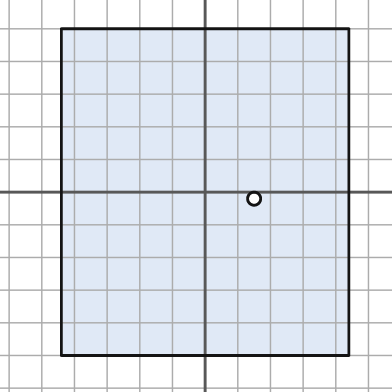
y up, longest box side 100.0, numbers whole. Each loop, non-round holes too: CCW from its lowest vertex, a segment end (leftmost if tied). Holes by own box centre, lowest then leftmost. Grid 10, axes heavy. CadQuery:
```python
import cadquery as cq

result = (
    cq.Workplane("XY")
    .moveTo(-44.0, -50.0)
    .lineTo(44.0, -50.0)
    .lineTo(44.0, 50.0)
    .lineTo(-44.0, 50.0)
    .close()
    .moveTo(15.0, -2.0)
    .circle(2.0)
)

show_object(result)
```